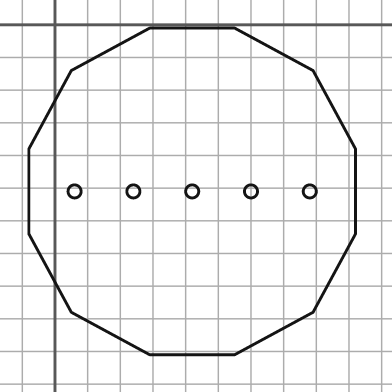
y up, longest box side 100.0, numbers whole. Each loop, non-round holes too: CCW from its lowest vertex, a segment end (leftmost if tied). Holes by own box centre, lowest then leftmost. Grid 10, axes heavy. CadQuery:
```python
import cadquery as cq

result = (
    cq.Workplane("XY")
    .moveTo(29.0, -101.0)
    .lineTo(55.0, -101.0)
    .lineTo(79.0, -88.0)
    .lineTo(92.0, -64.0)
    .lineTo(92.0, -38.0)
    .lineTo(79.0, -14.0)
    .lineTo(55.0, -1.0)
    .lineTo(29.0, -1.0)
    .lineTo(5.0, -14.0)
    .lineTo(-8.0, -38.0)
    .lineTo(-8.0, -64.0)
    .lineTo(5.0, -88.0)
    .close()
    .moveTo(6.0, -51.0)
    .circle(2.0)
    .moveTo(24.0, -51.0)
    .circle(2.0)
    .moveTo(42.0, -51.0)
    .circle(2.0)
    .moveTo(60.0, -51.0)
    .circle(2.0)
    .moveTo(78.0, -51.0)
    .circle(2.0)
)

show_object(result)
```